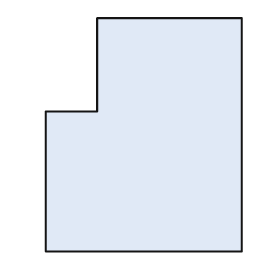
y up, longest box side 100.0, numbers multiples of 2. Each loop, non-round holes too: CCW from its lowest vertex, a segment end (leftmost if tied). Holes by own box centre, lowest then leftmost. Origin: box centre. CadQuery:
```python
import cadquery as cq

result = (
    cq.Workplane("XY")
    .moveTo(-42.0, -50.0)
    .lineTo(42.0, -50.0)
    .lineTo(42.0, 50.0)
    .lineTo(-20.0, 50.0)
    .lineTo(-20.0, 10.0)
    .lineTo(-42.0, 10.0)
    .close()
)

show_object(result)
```